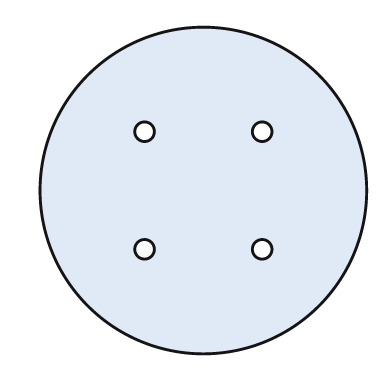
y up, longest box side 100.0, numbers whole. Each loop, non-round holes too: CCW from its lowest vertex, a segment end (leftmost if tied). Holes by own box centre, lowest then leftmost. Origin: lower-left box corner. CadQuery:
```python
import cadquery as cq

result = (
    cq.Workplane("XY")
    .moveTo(50.0, 50.0)
    .circle(50.0)
    .moveTo(32.0, 32.0)
    .circle(3.0)
    .moveTo(68.0, 32.0)
    .circle(3.0)
    .moveTo(32.0, 68.0)
    .circle(3.0)
    .moveTo(68.0, 68.0)
    .circle(3.0)
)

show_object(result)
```